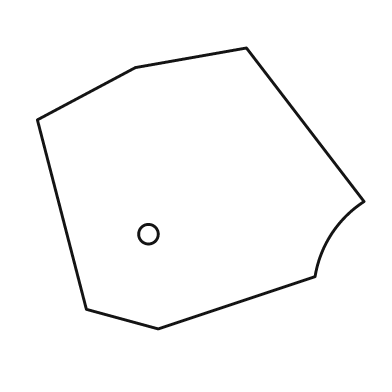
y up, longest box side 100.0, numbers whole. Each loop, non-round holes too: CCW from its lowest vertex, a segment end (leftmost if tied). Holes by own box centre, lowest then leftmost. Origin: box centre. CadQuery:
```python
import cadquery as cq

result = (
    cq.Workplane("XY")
    .moveTo(-13.0, -43.0)
    .lineTo(35.0, -27.0)
    .threePointArc((40.0, -14.0), (50.0, -4.0))
    .lineTo(14.0, 43.0)
    .lineTo(-20.0, 37.0)
    .lineTo(-50.0, 21.0)
    .lineTo(-35.0, -37.0)
    .close()
    .moveTo(-16.0, -14.0)
    .circle(3.0)
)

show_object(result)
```